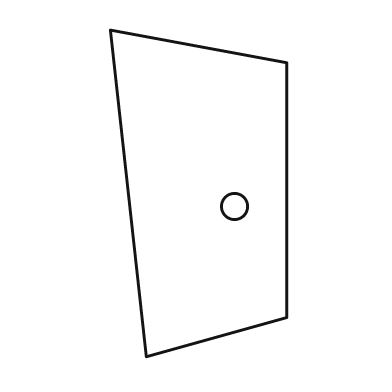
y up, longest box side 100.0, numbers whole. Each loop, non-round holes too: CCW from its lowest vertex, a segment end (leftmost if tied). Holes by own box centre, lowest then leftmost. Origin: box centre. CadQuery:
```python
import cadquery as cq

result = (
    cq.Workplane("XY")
    .moveTo(-16.0, -50.0)
    .lineTo(27.0, -38.0)
    .lineTo(27.0, 40.0)
    .lineTo(-27.0, 50.0)
    .close()
    .moveTo(11.0, -4.0)
    .circle(4.0)
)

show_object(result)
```